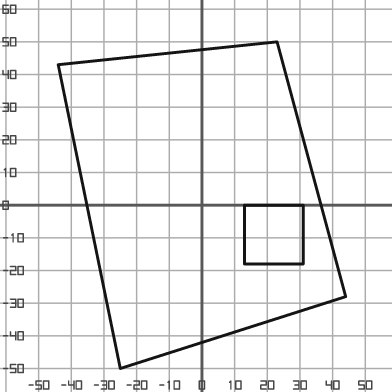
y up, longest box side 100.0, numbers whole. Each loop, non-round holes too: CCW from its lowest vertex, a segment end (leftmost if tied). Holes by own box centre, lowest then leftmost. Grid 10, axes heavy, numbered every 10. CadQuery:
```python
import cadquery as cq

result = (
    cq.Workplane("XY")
    .moveTo(-25.0, -50.0)
    .lineTo(44.0, -28.0)
    .lineTo(23.0, 50.0)
    .lineTo(-44.0, 43.0)
    .close()
    .moveTo(13.0, -18.0)
    .lineTo(31.0, -18.0)
    .lineTo(31.0, 0.0)
    .lineTo(13.0, 0.0)
    .close()
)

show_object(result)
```